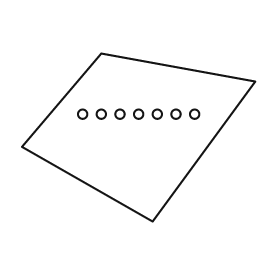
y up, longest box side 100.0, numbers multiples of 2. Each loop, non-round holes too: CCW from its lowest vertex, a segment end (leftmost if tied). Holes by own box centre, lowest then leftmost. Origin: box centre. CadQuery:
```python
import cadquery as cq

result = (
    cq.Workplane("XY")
    .moveTo(6.0, -36.0)
    .lineTo(50.0, 24.0)
    .lineTo(-16.0, 36.0)
    .lineTo(-50.0, -4.0)
    .close()
    .moveTo(-24.0, 10.0)
    .circle(2.0)
    .moveTo(-16.0, 10.0)
    .circle(2.0)
    .moveTo(-8.0, 10.0)
    .circle(2.0)
    .moveTo(0.0, 10.0)
    .circle(2.0)
    .moveTo(8.0, 10.0)
    .circle(2.0)
    .moveTo(16.0, 10.0)
    .circle(2.0)
    .moveTo(24.0, 10.0)
    .circle(2.0)
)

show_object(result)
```